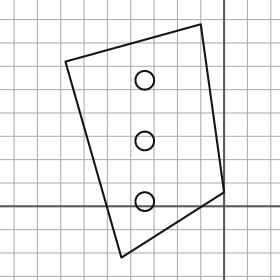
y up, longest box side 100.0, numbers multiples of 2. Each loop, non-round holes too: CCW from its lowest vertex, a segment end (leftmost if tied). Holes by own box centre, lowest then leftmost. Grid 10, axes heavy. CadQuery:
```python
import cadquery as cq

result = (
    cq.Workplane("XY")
    .moveTo(-44.0, -22.0)
    .lineTo(0.0, 6.0)
    .lineTo(-10.0, 78.0)
    .lineTo(-68.0, 62.0)
    .close()
    .moveTo(-34.0, 2.0)
    .circle(4.0)
    .moveTo(-34.0, 28.0)
    .circle(4.0)
    .moveTo(-34.0, 54.0)
    .circle(4.0)
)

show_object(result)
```